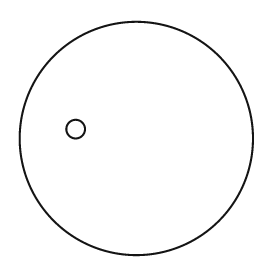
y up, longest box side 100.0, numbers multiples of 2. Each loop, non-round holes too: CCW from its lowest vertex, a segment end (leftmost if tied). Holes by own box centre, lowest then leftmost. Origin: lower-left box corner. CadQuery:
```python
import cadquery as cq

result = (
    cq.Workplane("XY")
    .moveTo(50.0, 50.0)
    .circle(50.0)
    .moveTo(24.0, 54.0)
    .circle(4.0)
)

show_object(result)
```